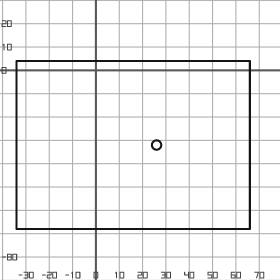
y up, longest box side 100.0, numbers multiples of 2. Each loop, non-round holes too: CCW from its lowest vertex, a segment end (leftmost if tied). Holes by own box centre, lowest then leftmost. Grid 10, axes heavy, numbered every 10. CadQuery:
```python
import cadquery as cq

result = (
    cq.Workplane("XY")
    .moveTo(-34.0, -68.0)
    .lineTo(66.0, -68.0)
    .lineTo(66.0, 4.0)
    .lineTo(-34.0, 4.0)
    .close()
    .moveTo(26.0, -32.0)
    .circle(2.0)
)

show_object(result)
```